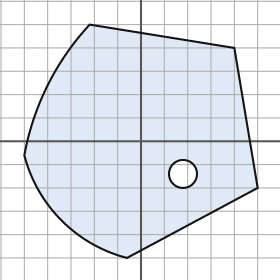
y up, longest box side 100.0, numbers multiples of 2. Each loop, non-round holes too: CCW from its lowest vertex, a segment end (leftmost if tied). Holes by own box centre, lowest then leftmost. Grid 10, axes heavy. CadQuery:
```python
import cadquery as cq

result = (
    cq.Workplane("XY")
    .moveTo(-6.0, -50.0)
    .lineTo(50.0, -20.0)
    .lineTo(40.0, 40.0)
    .lineTo(-22.0, 50.0)
    .threePointArc((-40.0, 24.0), (-50.0, -6.0))
    .threePointArc((-34.0, -34.0), (-6.0, -50.0))
    .close()
    .moveTo(18.0, -14.0)
    .circle(6.0)
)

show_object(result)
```